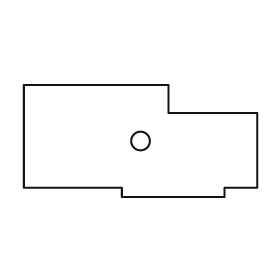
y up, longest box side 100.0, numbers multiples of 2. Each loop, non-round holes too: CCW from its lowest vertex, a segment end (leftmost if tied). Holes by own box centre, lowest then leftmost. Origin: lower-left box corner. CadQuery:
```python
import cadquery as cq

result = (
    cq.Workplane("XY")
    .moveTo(42.0, 0.0)
    .lineTo(86.0, 0.0)
    .lineTo(86.0, 4.0)
    .lineTo(100.0, 4.0)
    .lineTo(100.0, 36.0)
    .lineTo(62.0, 36.0)
    .lineTo(62.0, 48.0)
    .lineTo(0.0, 48.0)
    .lineTo(0.0, 4.0)
    .lineTo(42.0, 4.0)
    .close()
    .moveTo(50.0, 24.0)
    .circle(4.0)
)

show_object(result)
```